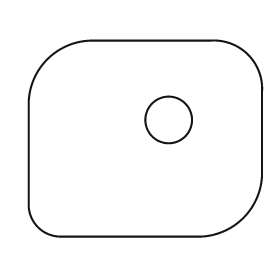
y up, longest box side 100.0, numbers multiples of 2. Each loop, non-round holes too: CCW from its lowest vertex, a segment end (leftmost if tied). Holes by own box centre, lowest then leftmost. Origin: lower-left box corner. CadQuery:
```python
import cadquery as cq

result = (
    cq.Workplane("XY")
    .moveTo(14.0, 0.0)
    .lineTo(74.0, 0.0)
    .threePointArc((92.0, 8.0), (100.0, 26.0))
    .lineTo(100.0, 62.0)
    .threePointArc((94.0, 78.0), (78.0, 84.0))
    .lineTo(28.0, 84.0)
    .threePointArc((8.0, 76.0), (0.0, 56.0))
    .lineTo(0.0, 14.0)
    .threePointArc((4.0, 4.0), (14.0, 0.0))
    .close()
    .moveTo(60.0, 50.0)
    .circle(10.0)
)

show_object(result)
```